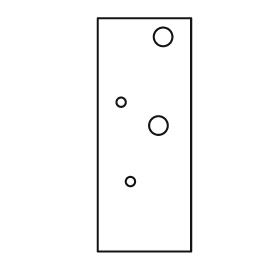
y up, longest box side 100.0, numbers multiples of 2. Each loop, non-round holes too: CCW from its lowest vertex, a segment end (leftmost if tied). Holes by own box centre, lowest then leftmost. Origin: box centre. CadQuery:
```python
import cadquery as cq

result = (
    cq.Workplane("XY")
    .moveTo(-20.0, -50.0)
    .lineTo(20.0, -50.0)
    .lineTo(20.0, 50.0)
    .lineTo(-20.0, 50.0)
    .close()
    .moveTo(-6.0, -20.0)
    .circle(2.0)
    .moveTo(6.0, 4.0)
    .circle(4.0)
    .moveTo(-10.0, 14.0)
    .circle(2.0)
    .moveTo(8.0, 42.0)
    .circle(4.0)
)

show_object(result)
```